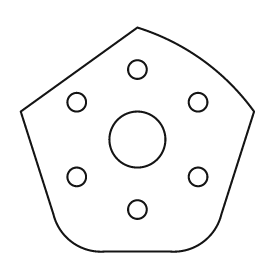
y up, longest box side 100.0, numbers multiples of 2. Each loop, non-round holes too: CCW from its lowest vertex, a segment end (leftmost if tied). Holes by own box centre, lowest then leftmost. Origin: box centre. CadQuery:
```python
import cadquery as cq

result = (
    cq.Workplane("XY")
    .moveTo(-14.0, -48.0)
    .lineTo(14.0, -48.0)
    .threePointArc((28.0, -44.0), (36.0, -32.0))
    .lineTo(50.0, 12.0)
    .threePointArc((28.0, 34.0), (0.0, 48.0))
    .lineTo(-50.0, 12.0)
    .lineTo(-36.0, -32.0)
    .threePointArc((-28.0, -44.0), (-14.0, -48.0))
    .close()
    .moveTo(0.0, -30.0)
    .circle(4.0)
    .moveTo(-26.0, -16.0)
    .circle(4.0)
    .moveTo(26.0, -16.0)
    .circle(4.0)
    .moveTo(0.0, 0.0)
    .circle(12.0)
    .moveTo(-26.0, 16.0)
    .circle(4.0)
    .moveTo(26.0, 16.0)
    .circle(4.0)
    .moveTo(0.0, 30.0)
    .circle(4.0)
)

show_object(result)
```